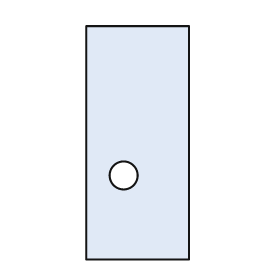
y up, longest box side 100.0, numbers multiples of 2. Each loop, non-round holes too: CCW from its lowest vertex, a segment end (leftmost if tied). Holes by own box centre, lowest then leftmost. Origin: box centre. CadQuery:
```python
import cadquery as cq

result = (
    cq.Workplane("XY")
    .moveTo(-22.0, -50.0)
    .lineTo(22.0, -50.0)
    .lineTo(22.0, 50.0)
    .lineTo(-22.0, 50.0)
    .close()
    .moveTo(-6.0, -14.0)
    .circle(6.0)
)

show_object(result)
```